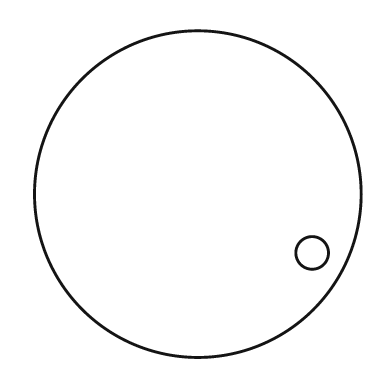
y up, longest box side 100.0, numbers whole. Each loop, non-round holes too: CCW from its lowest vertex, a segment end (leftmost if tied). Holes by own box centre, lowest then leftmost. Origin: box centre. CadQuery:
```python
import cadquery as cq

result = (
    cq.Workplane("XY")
    .moveTo(0.0, 0.0)
    .circle(50.0)
    .moveTo(35.0, -18.0)
    .circle(5.0)
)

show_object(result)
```